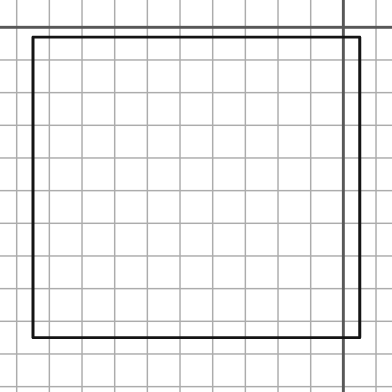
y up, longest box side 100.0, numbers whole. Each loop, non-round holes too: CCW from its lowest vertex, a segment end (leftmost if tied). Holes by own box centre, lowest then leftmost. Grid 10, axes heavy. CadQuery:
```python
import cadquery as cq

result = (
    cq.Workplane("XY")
    .moveTo(-95.0, -95.0)
    .lineTo(5.0, -95.0)
    .lineTo(5.0, -3.0)
    .lineTo(-95.0, -3.0)
    .close()
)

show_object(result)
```